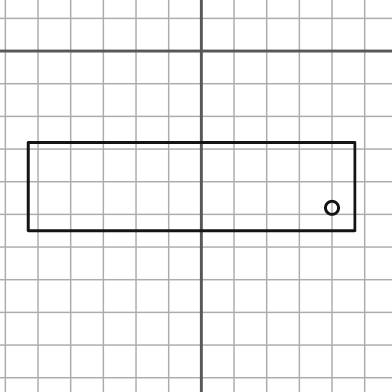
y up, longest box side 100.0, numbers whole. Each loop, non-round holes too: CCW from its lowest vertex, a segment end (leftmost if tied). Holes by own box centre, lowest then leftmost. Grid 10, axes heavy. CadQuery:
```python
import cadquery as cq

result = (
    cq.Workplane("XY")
    .moveTo(-53.0, -55.0)
    .lineTo(47.0, -55.0)
    .lineTo(47.0, -28.0)
    .lineTo(-53.0, -28.0)
    .close()
    .moveTo(40.0, -48.0)
    .circle(2.0)
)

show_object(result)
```